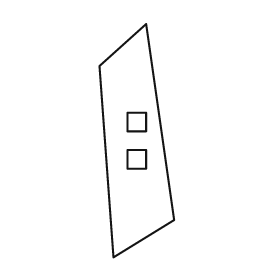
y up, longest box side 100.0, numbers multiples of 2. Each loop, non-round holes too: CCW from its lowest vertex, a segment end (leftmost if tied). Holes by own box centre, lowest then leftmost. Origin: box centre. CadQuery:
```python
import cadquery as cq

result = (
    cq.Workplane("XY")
    .moveTo(-10.0, -50.0)
    .lineTo(16.0, -34.0)
    .lineTo(4.0, 50.0)
    .lineTo(-16.0, 32.0)
    .close()
    .moveTo(-4.0, -12.0)
    .lineTo(4.0, -12.0)
    .lineTo(4.0, -4.0)
    .lineTo(-4.0, -4.0)
    .close()
    .moveTo(-4.0, 4.0)
    .lineTo(4.0, 4.0)
    .lineTo(4.0, 12.0)
    .lineTo(-4.0, 12.0)
    .close()
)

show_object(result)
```